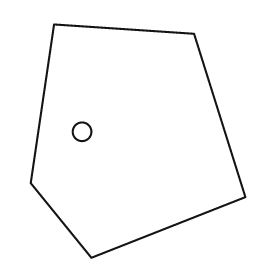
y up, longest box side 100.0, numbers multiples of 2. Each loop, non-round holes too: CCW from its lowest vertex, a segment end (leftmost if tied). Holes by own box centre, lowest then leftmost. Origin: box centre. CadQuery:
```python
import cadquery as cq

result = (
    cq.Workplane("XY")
    .moveTo(-20.0, -50.0)
    .lineTo(46.0, -24.0)
    .lineTo(24.0, 46.0)
    .lineTo(-36.0, 50.0)
    .lineTo(-46.0, -18.0)
    .close()
    .moveTo(-24.0, 4.0)
    .circle(4.0)
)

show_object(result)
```